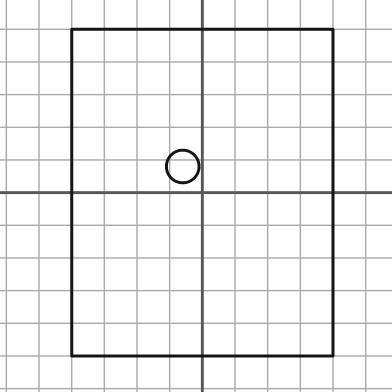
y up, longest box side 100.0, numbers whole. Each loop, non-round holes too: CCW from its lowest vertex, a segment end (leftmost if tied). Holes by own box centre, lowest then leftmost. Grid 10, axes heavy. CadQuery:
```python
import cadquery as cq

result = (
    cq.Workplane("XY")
    .moveTo(-40.0, -50.0)
    .lineTo(40.0, -50.0)
    .lineTo(40.0, 50.0)
    .lineTo(-40.0, 50.0)
    .close()
    .moveTo(-6.0, 8.0)
    .circle(5.0)
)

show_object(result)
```